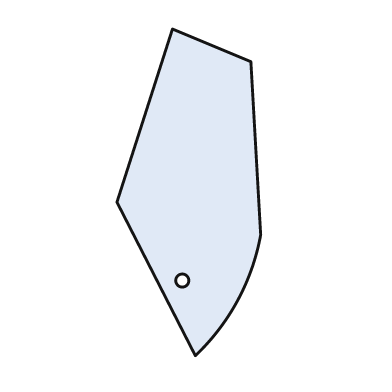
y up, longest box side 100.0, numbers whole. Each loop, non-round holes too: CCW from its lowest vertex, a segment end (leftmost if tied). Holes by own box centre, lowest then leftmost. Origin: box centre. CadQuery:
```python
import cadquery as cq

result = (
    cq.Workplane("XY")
    .moveTo(2.0, -50.0)
    .threePointArc((15.0, -33.0), (22.0, -13.0))
    .lineTo(19.0, 40.0)
    .lineTo(-5.0, 50.0)
    .lineTo(-22.0, -3.0)
    .close()
    .moveTo(-2.0, -27.0)
    .circle(2.0)
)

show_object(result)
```